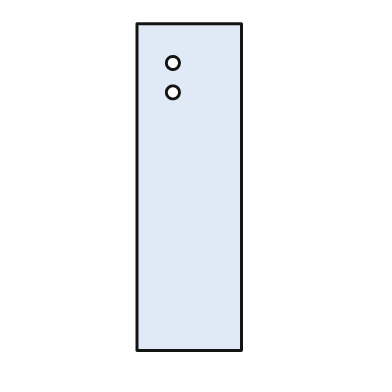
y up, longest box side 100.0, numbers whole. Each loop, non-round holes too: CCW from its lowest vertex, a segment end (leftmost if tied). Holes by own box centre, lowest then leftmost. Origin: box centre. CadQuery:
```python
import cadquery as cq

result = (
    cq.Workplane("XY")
    .moveTo(-16.0, -50.0)
    .lineTo(16.0, -50.0)
    .lineTo(16.0, 50.0)
    .lineTo(-16.0, 50.0)
    .close()
    .moveTo(-5.0, 29.0)
    .circle(2.0)
    .moveTo(-5.0, 38.0)
    .circle(2.0)
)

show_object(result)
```